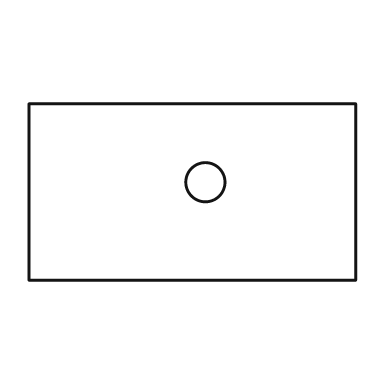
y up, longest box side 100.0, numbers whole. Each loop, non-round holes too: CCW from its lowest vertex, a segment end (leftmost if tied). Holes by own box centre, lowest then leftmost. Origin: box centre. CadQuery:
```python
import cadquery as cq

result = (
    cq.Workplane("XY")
    .moveTo(-50.0, -27.0)
    .lineTo(50.0, -27.0)
    .lineTo(50.0, 27.0)
    .lineTo(-50.0, 27.0)
    .close()
    .moveTo(4.0, 3.0)
    .circle(6.0)
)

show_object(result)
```